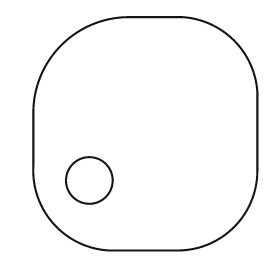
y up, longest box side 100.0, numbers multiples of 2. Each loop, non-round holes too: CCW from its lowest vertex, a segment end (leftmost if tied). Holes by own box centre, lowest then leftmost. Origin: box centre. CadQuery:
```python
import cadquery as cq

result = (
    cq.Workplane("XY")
    .moveTo(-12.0, -50.0)
    .lineTo(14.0, -50.0)
    .threePointArc((38.0, -40.0), (48.0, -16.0))
    .lineTo(48.0, 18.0)
    .threePointArc((38.0, 40.0), (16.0, 50.0))
    .lineTo(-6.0, 50.0)
    .threePointArc((-36.0, 38.0), (-48.0, 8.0))
    .lineTo(-48.0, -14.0)
    .threePointArc((-38.0, -40.0), (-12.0, -50.0))
    .close()
    .moveTo(-24.0, -20.0)
    .circle(10.0)
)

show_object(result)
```